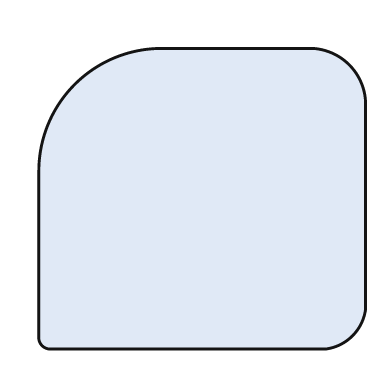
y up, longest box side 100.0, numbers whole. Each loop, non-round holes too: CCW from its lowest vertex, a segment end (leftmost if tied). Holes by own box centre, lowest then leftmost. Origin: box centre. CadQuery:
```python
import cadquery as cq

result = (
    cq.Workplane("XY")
    .moveTo(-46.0, -46.0)
    .lineTo(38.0, -46.0)
    .threePointArc((46.0, -42.0), (50.0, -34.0))
    .lineTo(50.0, 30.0)
    .threePointArc((45.0, 41.0), (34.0, 46.0))
    .lineTo(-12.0, 46.0)
    .threePointArc((-39.0, 35.0), (-50.0, 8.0))
    .lineTo(-50.0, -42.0)
    .threePointArc((-49.0, -45.0), (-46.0, -46.0))
    .close()
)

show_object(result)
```